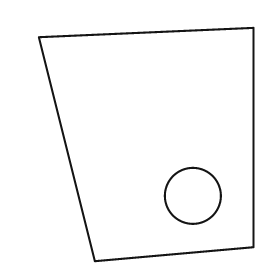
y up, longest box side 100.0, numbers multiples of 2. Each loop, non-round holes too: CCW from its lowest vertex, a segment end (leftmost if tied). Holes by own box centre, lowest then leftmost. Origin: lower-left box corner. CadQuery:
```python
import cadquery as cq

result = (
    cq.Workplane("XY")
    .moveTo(24.0, 0.0)
    .lineTo(92.0, 6.0)
    .lineTo(92.0, 100.0)
    .lineTo(0.0, 96.0)
    .close()
    .moveTo(66.0, 28.0)
    .circle(12.0)
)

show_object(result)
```